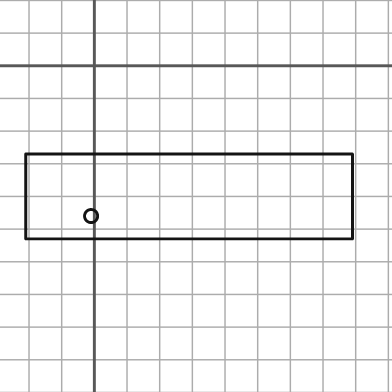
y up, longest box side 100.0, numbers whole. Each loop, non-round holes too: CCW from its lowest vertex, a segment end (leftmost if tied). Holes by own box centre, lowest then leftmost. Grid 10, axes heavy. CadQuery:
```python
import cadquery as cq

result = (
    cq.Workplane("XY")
    .moveTo(-21.0, -53.0)
    .lineTo(79.0, -53.0)
    .lineTo(79.0, -27.0)
    .lineTo(-21.0, -27.0)
    .close()
    .moveTo(-1.0, -46.0)
    .circle(2.0)
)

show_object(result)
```